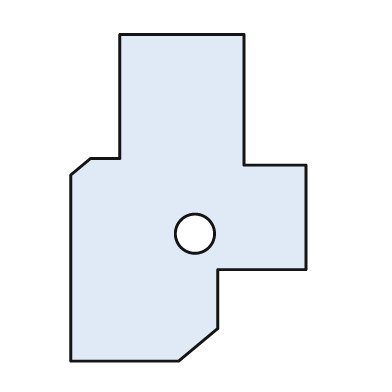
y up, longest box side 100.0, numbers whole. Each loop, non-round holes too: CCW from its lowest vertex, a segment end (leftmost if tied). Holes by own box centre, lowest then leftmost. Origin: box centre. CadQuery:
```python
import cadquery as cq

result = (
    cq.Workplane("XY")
    .moveTo(-36.0, -50.0)
    .lineTo(-3.0, -50.0)
    .lineTo(9.0, -40.0)
    .lineTo(9.0, -22.0)
    .lineTo(36.0, -22.0)
    .lineTo(36.0, 10.0)
    .lineTo(17.0, 10.0)
    .lineTo(17.0, 50.0)
    .lineTo(-21.0, 50.0)
    .lineTo(-21.0, 12.0)
    .lineTo(-30.0, 12.0)
    .lineTo(-36.0, 7.0)
    .close()
    .moveTo(2.0, -11.0)
    .circle(6.0)
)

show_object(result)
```